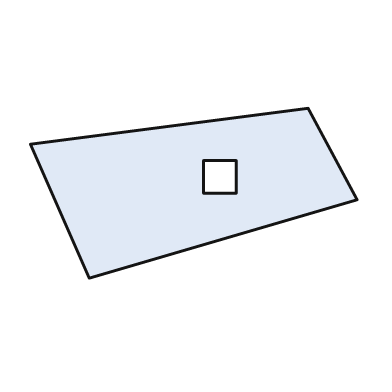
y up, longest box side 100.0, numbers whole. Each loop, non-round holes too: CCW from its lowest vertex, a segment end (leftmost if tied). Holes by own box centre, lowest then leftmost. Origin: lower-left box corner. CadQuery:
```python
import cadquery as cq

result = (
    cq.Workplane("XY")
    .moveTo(18.0, 0.0)
    .lineTo(100.0, 24.0)
    .lineTo(85.0, 52.0)
    .lineTo(0.0, 41.0)
    .close()
    .moveTo(53.0, 26.0)
    .lineTo(63.0, 26.0)
    .lineTo(63.0, 36.0)
    .lineTo(53.0, 36.0)
    .close()
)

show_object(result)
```